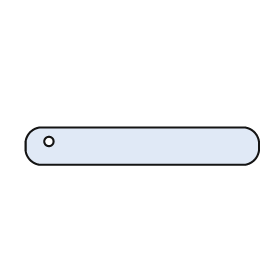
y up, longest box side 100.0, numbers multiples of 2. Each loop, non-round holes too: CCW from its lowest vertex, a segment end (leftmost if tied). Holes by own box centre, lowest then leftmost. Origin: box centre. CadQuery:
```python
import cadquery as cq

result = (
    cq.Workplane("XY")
    .moveTo(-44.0, -8.0)
    .lineTo(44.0, -8.0)
    .threePointArc((48.0, -6.0), (50.0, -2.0))
    .lineTo(50.0, 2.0)
    .threePointArc((48.0, 6.0), (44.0, 8.0))
    .lineTo(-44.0, 8.0)
    .threePointArc((-48.0, 6.0), (-50.0, 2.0))
    .lineTo(-50.0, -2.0)
    .threePointArc((-48.0, -6.0), (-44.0, -8.0))
    .close()
    .moveTo(-40.0, 2.0)
    .circle(2.0)
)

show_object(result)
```